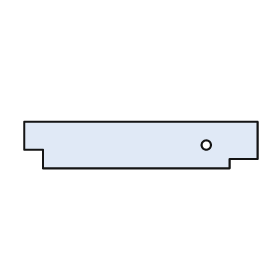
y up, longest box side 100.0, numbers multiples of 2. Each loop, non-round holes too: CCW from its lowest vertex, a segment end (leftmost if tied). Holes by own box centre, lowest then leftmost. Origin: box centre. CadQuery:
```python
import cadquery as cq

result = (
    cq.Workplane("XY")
    .moveTo(-42.0, -10.0)
    .lineTo(38.0, -10.0)
    .lineTo(38.0, -6.0)
    .lineTo(50.0, -6.0)
    .lineTo(50.0, 10.0)
    .lineTo(-50.0, 10.0)
    .lineTo(-50.0, -2.0)
    .lineTo(-42.0, -2.0)
    .close()
    .moveTo(28.0, 0.0)
    .circle(2.0)
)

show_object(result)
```